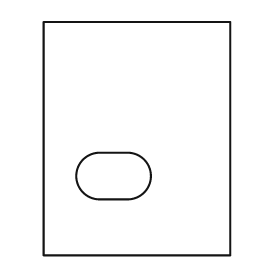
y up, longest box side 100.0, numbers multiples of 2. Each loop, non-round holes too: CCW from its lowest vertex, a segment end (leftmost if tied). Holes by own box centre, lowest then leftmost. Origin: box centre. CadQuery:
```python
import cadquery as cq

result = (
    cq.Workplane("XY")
    .moveTo(-40.0, -50.0)
    .lineTo(40.0, -50.0)
    .lineTo(40.0, 50.0)
    .lineTo(-40.0, 50.0)
    .close()
    .moveTo(-16.0, -26.0)
    .lineTo(-4.0, -26.0)
    .threePointArc((6.0, -16.0), (-4.0, -6.0))
    .lineTo(-16.0, -6.0)
    .threePointArc((-26.0, -16.0), (-16.0, -26.0))
    .close()
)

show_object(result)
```